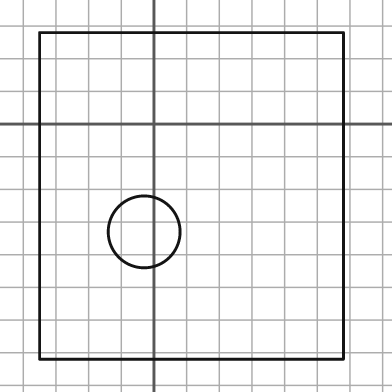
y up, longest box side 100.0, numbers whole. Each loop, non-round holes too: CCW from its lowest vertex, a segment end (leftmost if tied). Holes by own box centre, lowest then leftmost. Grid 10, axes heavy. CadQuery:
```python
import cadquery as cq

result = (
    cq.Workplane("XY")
    .moveTo(-35.0, -72.0)
    .lineTo(58.0, -72.0)
    .lineTo(58.0, 28.0)
    .lineTo(-35.0, 28.0)
    .close()
    .moveTo(-3.0, -33.0)
    .circle(11.0)
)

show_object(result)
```